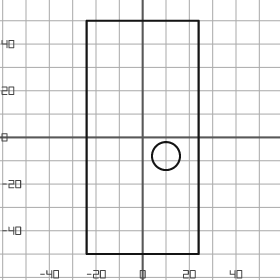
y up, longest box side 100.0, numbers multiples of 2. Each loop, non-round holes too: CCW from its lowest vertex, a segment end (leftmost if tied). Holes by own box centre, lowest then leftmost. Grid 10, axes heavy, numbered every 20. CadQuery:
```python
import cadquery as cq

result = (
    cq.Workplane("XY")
    .moveTo(-24.0, -50.0)
    .lineTo(24.0, -50.0)
    .lineTo(24.0, 50.0)
    .lineTo(-24.0, 50.0)
    .close()
    .moveTo(10.0, -8.0)
    .circle(6.0)
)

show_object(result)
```